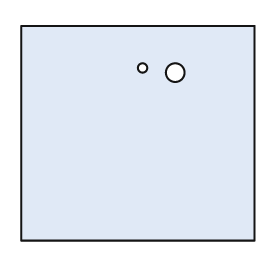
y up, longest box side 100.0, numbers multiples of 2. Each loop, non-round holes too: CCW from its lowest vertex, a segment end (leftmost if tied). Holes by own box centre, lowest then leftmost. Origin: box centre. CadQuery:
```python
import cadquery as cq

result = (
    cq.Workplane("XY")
    .moveTo(-50.0, -46.0)
    .lineTo(50.0, -46.0)
    .lineTo(50.0, 46.0)
    .lineTo(-50.0, 46.0)
    .close()
    .moveTo(16.0, 26.0)
    .circle(4.0)
    .moveTo(2.0, 28.0)
    .circle(2.0)
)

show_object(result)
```